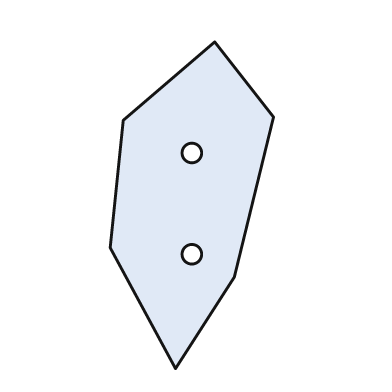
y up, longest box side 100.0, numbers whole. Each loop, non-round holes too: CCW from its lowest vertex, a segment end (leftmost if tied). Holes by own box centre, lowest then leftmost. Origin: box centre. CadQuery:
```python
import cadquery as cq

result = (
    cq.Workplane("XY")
    .moveTo(-5.0, -50.0)
    .lineTo(13.0, -22.0)
    .lineTo(25.0, 27.0)
    .lineTo(7.0, 50.0)
    .lineTo(-21.0, 26.0)
    .lineTo(-25.0, -13.0)
    .close()
    .moveTo(0.0, -15.0)
    .circle(3.0)
    .moveTo(0.0, 16.0)
    .circle(3.0)
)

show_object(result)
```